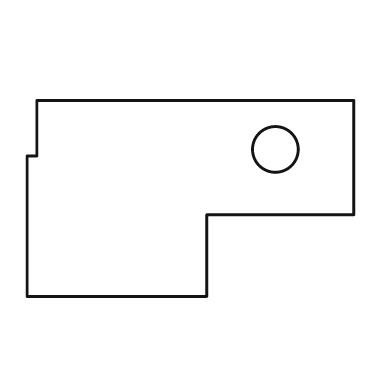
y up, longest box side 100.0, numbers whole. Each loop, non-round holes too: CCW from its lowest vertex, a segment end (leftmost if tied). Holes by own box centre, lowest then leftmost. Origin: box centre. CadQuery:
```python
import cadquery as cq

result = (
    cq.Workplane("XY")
    .moveTo(-50.0, -30.0)
    .lineTo(5.0, -30.0)
    .lineTo(5.0, -5.0)
    .lineTo(50.0, -5.0)
    .lineTo(50.0, 30.0)
    .lineTo(-47.0, 30.0)
    .lineTo(-47.0, 13.0)
    .lineTo(-50.0, 13.0)
    .close()
    .moveTo(26.0, 15.0)
    .circle(7.0)
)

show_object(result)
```